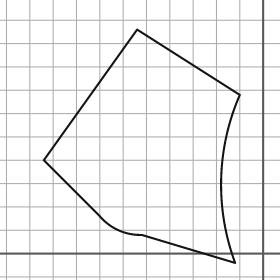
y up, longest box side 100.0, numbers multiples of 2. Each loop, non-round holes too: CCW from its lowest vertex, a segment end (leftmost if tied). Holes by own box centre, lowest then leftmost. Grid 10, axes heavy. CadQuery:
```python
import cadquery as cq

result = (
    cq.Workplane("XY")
    .moveTo(-12.0, -4.0)
    .threePointArc((-18.0, 32.0), (-10.0, 68.0))
    .lineTo(-54.0, 96.0)
    .lineTo(-94.0, 40.0)
    .lineTo(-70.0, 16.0)
    .threePointArc((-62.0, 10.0), (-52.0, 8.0))
    .close()
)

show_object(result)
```